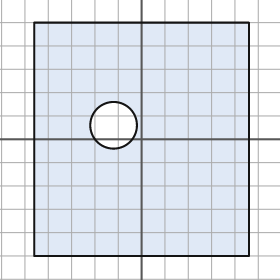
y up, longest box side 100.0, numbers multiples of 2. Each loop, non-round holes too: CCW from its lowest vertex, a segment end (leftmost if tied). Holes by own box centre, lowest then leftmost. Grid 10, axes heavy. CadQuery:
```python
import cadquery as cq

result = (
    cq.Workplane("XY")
    .moveTo(-46.0, -50.0)
    .lineTo(46.0, -50.0)
    .lineTo(46.0, 50.0)
    .lineTo(-46.0, 50.0)
    .close()
    .moveTo(-12.0, 6.0)
    .circle(10.0)
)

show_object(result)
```